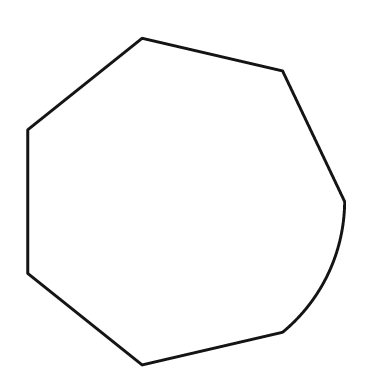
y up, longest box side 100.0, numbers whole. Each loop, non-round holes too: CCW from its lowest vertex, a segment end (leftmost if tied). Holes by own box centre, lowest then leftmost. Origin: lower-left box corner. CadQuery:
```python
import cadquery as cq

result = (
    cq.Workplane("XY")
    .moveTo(35.0, 0.0)
    .lineTo(78.0, 10.0)
    .threePointArc((92.0, 28.0), (97.0, 50.0))
    .lineTo(78.0, 90.0)
    .lineTo(35.0, 100.0)
    .lineTo(0.0, 72.0)
    .lineTo(0.0, 28.0)
    .close()
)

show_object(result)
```